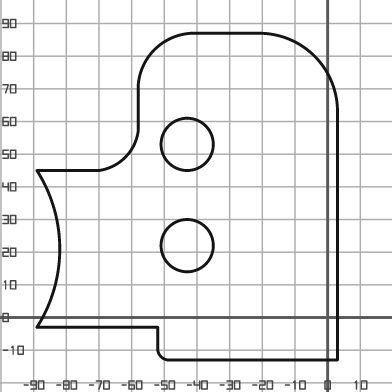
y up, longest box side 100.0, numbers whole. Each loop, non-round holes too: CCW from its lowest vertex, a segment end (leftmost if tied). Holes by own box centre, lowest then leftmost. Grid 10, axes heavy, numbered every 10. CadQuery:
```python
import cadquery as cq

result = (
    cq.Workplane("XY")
    .moveTo(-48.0, -13.0)
    .lineTo(3.0, -13.0)
    .lineTo(3.0, 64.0)
    .threePointArc((-4.0, 80.0), (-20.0, 87.0))
    .lineTo(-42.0, 87.0)
    .threePointArc((-53.0, 82.0), (-58.0, 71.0))
    .lineTo(-58.0, 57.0)
    .threePointArc((-62.0, 49.0), (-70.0, 45.0))
    .lineTo(-89.0, 45.0)
    .threePointArc((-82.0, 21.0), (-89.0, -3.0))
    .lineTo(-52.0, -3.0)
    .lineTo(-52.0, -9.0)
    .threePointArc((-51.0, -12.0), (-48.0, -13.0))
    .close()
    .moveTo(-43.0, 22.0)
    .circle(8.0)
    .moveTo(-43.0, 53.0)
    .circle(8.0)
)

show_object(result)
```